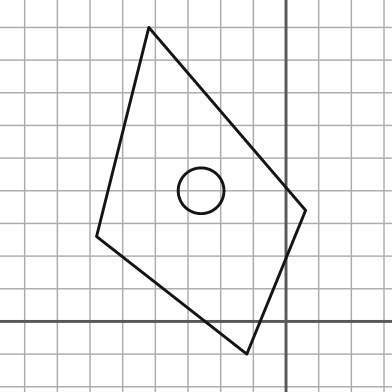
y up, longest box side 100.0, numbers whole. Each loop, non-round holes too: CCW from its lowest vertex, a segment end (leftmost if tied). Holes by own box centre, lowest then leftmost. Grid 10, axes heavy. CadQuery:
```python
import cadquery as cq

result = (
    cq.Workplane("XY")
    .moveTo(-12.0, -10.0)
    .lineTo(6.0, 34.0)
    .lineTo(-42.0, 90.0)
    .lineTo(-58.0, 26.0)
    .close()
    .moveTo(-26.0, 40.0)
    .circle(7.0)
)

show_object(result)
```